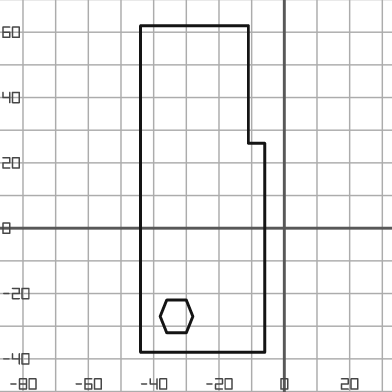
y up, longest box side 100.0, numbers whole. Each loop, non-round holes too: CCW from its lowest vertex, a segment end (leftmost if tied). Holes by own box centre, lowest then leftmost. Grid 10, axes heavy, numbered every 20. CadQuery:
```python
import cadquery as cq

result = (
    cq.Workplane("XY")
    .moveTo(-44.0, -38.0)
    .lineTo(-6.0, -38.0)
    .lineTo(-6.0, 26.0)
    .lineTo(-11.0, 26.0)
    .lineTo(-11.0, 62.0)
    .lineTo(-44.0, 62.0)
    .close()
    .moveTo(-36.0, -32.0)
    .lineTo(-30.0, -32.0)
    .lineTo(-28.0, -27.0)
    .lineTo(-30.0, -22.0)
    .lineTo(-36.0, -22.0)
    .lineTo(-38.0, -27.0)
    .close()
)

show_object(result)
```